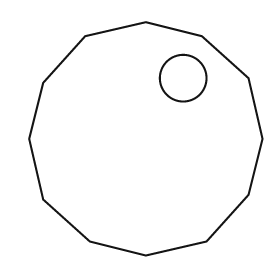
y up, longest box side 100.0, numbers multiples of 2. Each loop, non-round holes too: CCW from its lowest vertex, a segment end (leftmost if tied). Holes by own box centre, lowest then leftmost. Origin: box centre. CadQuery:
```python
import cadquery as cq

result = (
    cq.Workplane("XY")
    .moveTo(0.0, -50.0)
    .lineTo(26.0, -44.0)
    .lineTo(44.0, -24.0)
    .lineTo(50.0, 0.0)
    .lineTo(44.0, 26.0)
    .lineTo(24.0, 44.0)
    .lineTo(0.0, 50.0)
    .lineTo(-26.0, 44.0)
    .lineTo(-44.0, 24.0)
    .lineTo(-50.0, 0.0)
    .lineTo(-44.0, -26.0)
    .lineTo(-24.0, -44.0)
    .close()
    .moveTo(16.0, 26.0)
    .circle(10.0)
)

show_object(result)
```